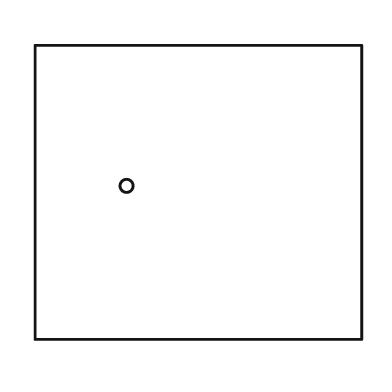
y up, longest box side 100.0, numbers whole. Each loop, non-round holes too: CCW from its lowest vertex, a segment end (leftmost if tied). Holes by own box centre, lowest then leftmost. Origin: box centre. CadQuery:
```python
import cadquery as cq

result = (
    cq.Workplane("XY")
    .moveTo(-50.0, -45.0)
    .lineTo(50.0, -45.0)
    .lineTo(50.0, 45.0)
    .lineTo(-50.0, 45.0)
    .close()
    .moveTo(-22.0, 2.0)
    .circle(2.0)
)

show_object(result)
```